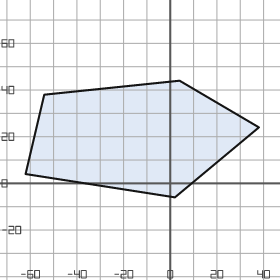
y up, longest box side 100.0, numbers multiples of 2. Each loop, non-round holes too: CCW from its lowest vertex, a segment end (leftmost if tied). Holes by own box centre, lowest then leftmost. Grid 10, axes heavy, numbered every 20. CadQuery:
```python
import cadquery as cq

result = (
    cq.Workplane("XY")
    .moveTo(2.0, -6.0)
    .lineTo(38.0, 24.0)
    .lineTo(4.0, 44.0)
    .lineTo(-54.0, 38.0)
    .lineTo(-62.0, 4.0)
    .close()
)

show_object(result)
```